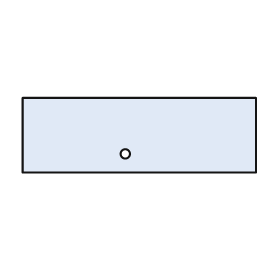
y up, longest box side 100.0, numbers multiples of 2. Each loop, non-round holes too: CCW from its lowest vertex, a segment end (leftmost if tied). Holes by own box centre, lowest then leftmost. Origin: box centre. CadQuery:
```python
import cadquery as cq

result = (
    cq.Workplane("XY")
    .moveTo(-50.0, -16.0)
    .lineTo(50.0, -16.0)
    .lineTo(50.0, 16.0)
    .lineTo(-50.0, 16.0)
    .close()
    .moveTo(-6.0, -8.0)
    .circle(2.0)
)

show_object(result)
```